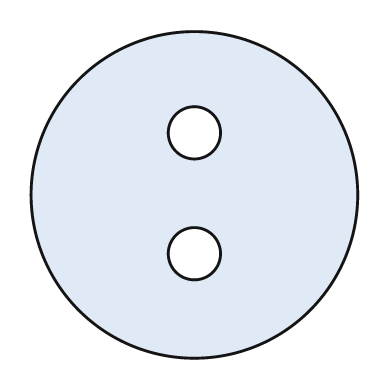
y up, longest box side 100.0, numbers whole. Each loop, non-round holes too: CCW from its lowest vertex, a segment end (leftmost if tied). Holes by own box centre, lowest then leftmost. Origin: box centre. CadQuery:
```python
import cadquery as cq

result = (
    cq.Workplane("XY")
    .moveTo(0.0, 0.0)
    .circle(50.0)
    .moveTo(0.0, -18.0)
    .circle(8.0)
    .moveTo(0.0, 19.0)
    .circle(8.0)
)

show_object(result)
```